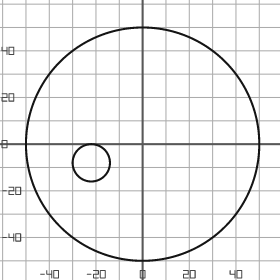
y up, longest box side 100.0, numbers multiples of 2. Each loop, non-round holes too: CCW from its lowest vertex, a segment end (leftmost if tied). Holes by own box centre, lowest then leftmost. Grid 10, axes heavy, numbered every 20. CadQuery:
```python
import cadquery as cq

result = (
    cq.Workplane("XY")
    .moveTo(0.0, 0.0)
    .circle(50.0)
    .moveTo(-22.0, -8.0)
    .circle(8.0)
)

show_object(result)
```